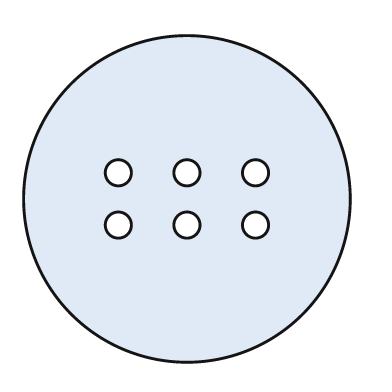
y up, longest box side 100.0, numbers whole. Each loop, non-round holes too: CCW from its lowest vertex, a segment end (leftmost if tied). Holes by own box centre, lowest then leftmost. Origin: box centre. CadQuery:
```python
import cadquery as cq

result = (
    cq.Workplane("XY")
    .moveTo(0.0, 0.0)
    .circle(50.0)
    .moveTo(-21.0, -8.0)
    .circle(4.0)
    .moveTo(0.0, -8.0)
    .circle(4.0)
    .moveTo(21.0, -8.0)
    .circle(4.0)
    .moveTo(-21.0, 8.0)
    .circle(4.0)
    .moveTo(0.0, 8.0)
    .circle(4.0)
    .moveTo(21.0, 8.0)
    .circle(4.0)
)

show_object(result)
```